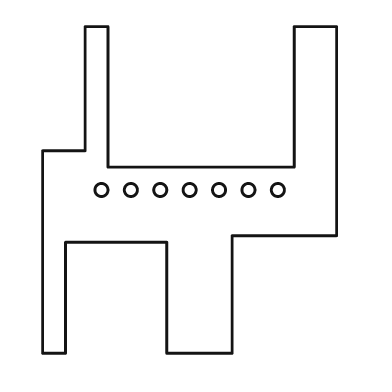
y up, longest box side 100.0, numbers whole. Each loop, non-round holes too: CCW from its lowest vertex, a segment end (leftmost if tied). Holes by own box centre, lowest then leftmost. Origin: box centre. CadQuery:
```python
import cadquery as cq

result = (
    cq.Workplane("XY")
    .moveTo(-45.0, -50.0)
    .lineTo(-38.0, -50.0)
    .lineTo(-38.0, -16.0)
    .lineTo(-7.0, -16.0)
    .lineTo(-7.0, -50.0)
    .lineTo(13.0, -50.0)
    .lineTo(13.0, -14.0)
    .lineTo(45.0, -14.0)
    .lineTo(45.0, 50.0)
    .lineTo(32.0, 50.0)
    .lineTo(32.0, 7.0)
    .lineTo(-25.0, 7.0)
    .lineTo(-25.0, 50.0)
    .lineTo(-32.0, 50.0)
    .lineTo(-32.0, 12.0)
    .lineTo(-45.0, 12.0)
    .close()
    .moveTo(-27.0, 0.0)
    .circle(2.0)
    .moveTo(-18.0, 0.0)
    .circle(2.0)
    .moveTo(-9.0, 0.0)
    .circle(2.0)
    .moveTo(0.0, 0.0)
    .circle(2.0)
    .moveTo(9.0, 0.0)
    .circle(2.0)
    .moveTo(18.0, 0.0)
    .circle(2.0)
    .moveTo(27.0, 0.0)
    .circle(2.0)
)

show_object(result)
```